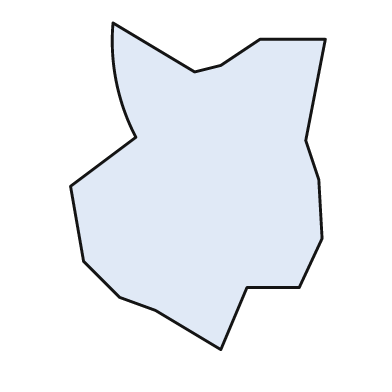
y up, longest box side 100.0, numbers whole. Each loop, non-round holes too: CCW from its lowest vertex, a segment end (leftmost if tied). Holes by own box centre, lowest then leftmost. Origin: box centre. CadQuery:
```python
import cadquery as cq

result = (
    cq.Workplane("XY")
    .moveTo(7.0, -50.0)
    .lineTo(15.0, -31.0)
    .lineTo(31.0, -31.0)
    .lineTo(38.0, -16.0)
    .lineTo(37.0, 2.0)
    .lineTo(33.0, 14.0)
    .lineTo(39.0, 45.0)
    .lineTo(19.0, 45.0)
    .lineTo(7.0, 37.0)
    .lineTo(-1.0, 35.0)
    .lineTo(-26.0, 50.0)
    .threePointArc((-25.0, 32.0), (-19.0, 15.0))
    .lineTo(-39.0, 0.0)
    .lineTo(-35.0, -23.0)
    .lineTo(-24.0, -34.0)
    .lineTo(-13.0, -38.0)
    .close()
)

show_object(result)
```